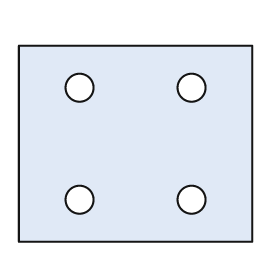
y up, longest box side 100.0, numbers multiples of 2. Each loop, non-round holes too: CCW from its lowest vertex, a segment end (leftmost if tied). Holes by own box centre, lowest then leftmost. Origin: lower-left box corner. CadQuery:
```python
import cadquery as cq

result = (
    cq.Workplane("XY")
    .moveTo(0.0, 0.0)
    .lineTo(100.0, 0.0)
    .lineTo(100.0, 84.0)
    .lineTo(0.0, 84.0)
    .close()
    .moveTo(26.0, 18.0)
    .circle(6.0)
    .moveTo(74.0, 18.0)
    .circle(6.0)
    .moveTo(26.0, 66.0)
    .circle(6.0)
    .moveTo(74.0, 66.0)
    .circle(6.0)
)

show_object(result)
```